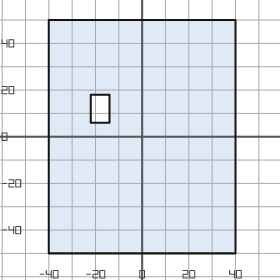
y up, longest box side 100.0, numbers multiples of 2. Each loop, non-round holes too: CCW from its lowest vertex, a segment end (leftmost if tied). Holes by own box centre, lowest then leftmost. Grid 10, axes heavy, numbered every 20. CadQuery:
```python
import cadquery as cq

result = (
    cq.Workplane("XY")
    .moveTo(-40.0, -50.0)
    .lineTo(40.0, -50.0)
    .lineTo(40.0, 50.0)
    .lineTo(-40.0, 50.0)
    .close()
    .moveTo(-22.0, 6.0)
    .lineTo(-14.0, 6.0)
    .lineTo(-14.0, 18.0)
    .lineTo(-22.0, 18.0)
    .close()
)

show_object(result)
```